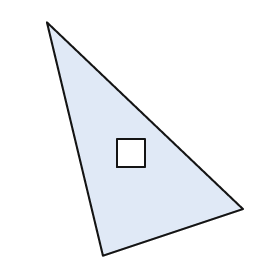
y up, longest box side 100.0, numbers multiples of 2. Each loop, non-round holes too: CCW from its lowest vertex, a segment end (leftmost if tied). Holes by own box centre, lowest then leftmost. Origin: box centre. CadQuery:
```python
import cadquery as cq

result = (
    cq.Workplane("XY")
    .moveTo(-18.0, -50.0)
    .lineTo(42.0, -30.0)
    .lineTo(-42.0, 50.0)
    .close()
    .moveTo(-12.0, -12.0)
    .lineTo(0.0, -12.0)
    .lineTo(0.0, 0.0)
    .lineTo(-12.0, 0.0)
    .close()
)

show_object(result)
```